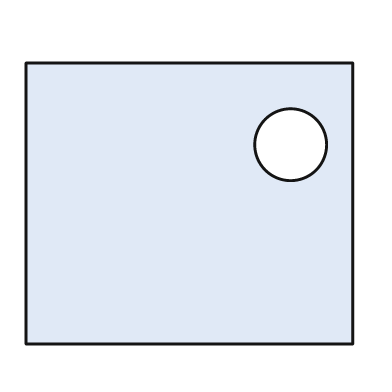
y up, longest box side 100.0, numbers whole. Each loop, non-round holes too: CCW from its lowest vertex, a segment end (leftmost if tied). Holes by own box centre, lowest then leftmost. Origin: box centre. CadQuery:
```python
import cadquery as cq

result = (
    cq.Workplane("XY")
    .moveTo(-50.0, -43.0)
    .lineTo(50.0, -43.0)
    .lineTo(50.0, 43.0)
    .lineTo(-50.0, 43.0)
    .close()
    .moveTo(31.0, 18.0)
    .circle(11.0)
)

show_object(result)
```